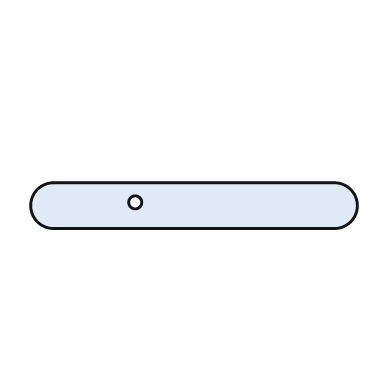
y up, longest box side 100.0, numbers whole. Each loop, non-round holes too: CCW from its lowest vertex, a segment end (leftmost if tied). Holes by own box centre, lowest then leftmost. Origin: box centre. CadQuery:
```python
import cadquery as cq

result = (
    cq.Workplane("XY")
    .moveTo(-43.0, -7.0)
    .lineTo(43.0, -7.0)
    .threePointArc((50.0, 0.0), (43.0, 7.0))
    .lineTo(-43.0, 7.0)
    .threePointArc((-50.0, 0.0), (-43.0, -7.0))
    .close()
    .moveTo(-18.0, 1.0)
    .circle(2.0)
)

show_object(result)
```